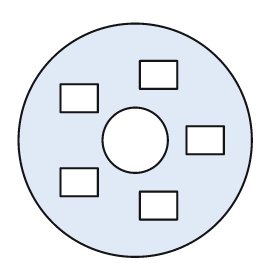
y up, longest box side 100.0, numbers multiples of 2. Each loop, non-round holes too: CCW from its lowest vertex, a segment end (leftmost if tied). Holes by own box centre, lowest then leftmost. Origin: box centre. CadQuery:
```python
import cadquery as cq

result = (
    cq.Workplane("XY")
    .moveTo(0.0, 0.0)
    .circle(50.0)
    .moveTo(2.0, -34.0)
    .lineTo(18.0, -34.0)
    .lineTo(18.0, -22.0)
    .lineTo(2.0, -22.0)
    .close()
    .moveTo(-32.0, -24.0)
    .lineTo(-16.0, -24.0)
    .lineTo(-16.0, -12.0)
    .lineTo(-32.0, -12.0)
    .close()
    .moveTo(0.0, 0.0)
    .circle(14.0)
    .moveTo(22.0, -6.0)
    .lineTo(38.0, -6.0)
    .lineTo(38.0, 6.0)
    .lineTo(22.0, 6.0)
    .close()
    .moveTo(-32.0, 12.0)
    .lineTo(-16.0, 12.0)
    .lineTo(-16.0, 24.0)
    .lineTo(-32.0, 24.0)
    .close()
    .moveTo(2.0, 22.0)
    .lineTo(18.0, 22.0)
    .lineTo(18.0, 34.0)
    .lineTo(2.0, 34.0)
    .close()
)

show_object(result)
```